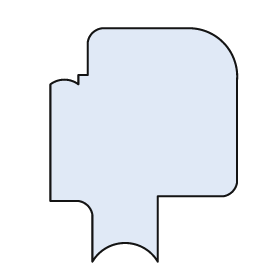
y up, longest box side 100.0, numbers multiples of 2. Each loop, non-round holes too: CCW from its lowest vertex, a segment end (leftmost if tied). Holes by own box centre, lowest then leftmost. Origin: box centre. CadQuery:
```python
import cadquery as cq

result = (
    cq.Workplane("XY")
    .moveTo(-22.0, -50.0)
    .threePointArc((-8.0, -42.0), (6.0, -50.0))
    .lineTo(6.0, -22.0)
    .lineTo(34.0, -22.0)
    .threePointArc((38.0, -20.0), (40.0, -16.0))
    .lineTo(40.0, 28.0)
    .threePointArc((34.0, 44.0), (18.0, 50.0))
    .lineTo(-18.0, 50.0)
    .threePointArc((-22.0, 48.0), (-24.0, 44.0))
    .lineTo(-24.0, 30.0)
    .lineTo(-28.0, 30.0)
    .lineTo(-28.0, 26.0)
    .threePointArc((-34.0, 28.0), (-40.0, 26.0))
    .lineTo(-40.0, -24.0)
    .lineTo(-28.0, -24.0)
    .threePointArc((-24.0, -26.0), (-22.0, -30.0))
    .close()
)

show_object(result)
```